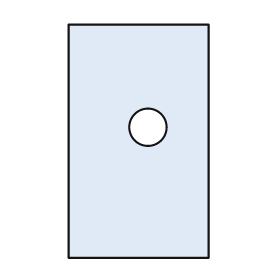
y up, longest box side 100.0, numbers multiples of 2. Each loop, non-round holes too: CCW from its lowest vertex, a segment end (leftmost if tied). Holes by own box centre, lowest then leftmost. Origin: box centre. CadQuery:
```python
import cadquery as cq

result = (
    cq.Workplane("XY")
    .moveTo(-30.0, -50.0)
    .lineTo(30.0, -50.0)
    .lineTo(30.0, 50.0)
    .lineTo(-30.0, 50.0)
    .close()
    .moveTo(4.0, 6.0)
    .circle(8.0)
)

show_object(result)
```